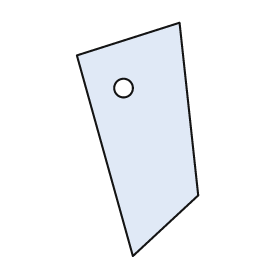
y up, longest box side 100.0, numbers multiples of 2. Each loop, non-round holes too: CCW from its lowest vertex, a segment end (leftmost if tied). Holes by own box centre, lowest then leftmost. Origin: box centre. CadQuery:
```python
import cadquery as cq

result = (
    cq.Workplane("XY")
    .moveTo(-2.0, -50.0)
    .lineTo(26.0, -24.0)
    .lineTo(18.0, 50.0)
    .lineTo(-26.0, 36.0)
    .close()
    .moveTo(-6.0, 22.0)
    .circle(4.0)
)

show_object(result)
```